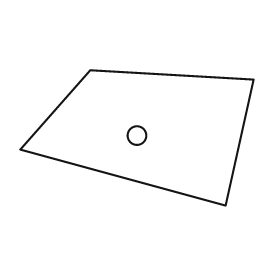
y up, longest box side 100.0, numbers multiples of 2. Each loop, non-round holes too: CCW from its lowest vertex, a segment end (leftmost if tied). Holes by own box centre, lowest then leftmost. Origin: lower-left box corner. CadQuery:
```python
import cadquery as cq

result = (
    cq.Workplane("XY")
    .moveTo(88.0, 0.0)
    .lineTo(100.0, 54.0)
    .lineTo(30.0, 58.0)
    .lineTo(0.0, 24.0)
    .close()
    .moveTo(50.0, 30.0)
    .circle(4.0)
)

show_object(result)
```